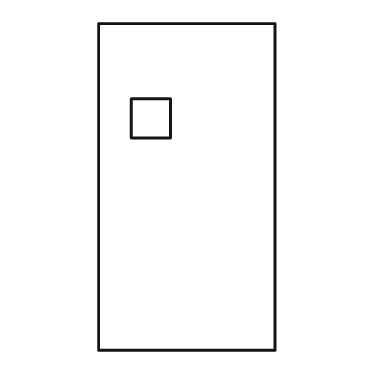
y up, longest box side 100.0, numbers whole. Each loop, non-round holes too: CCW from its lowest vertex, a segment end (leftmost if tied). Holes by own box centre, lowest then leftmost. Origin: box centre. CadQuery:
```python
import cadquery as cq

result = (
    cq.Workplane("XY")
    .moveTo(-27.0, -50.0)
    .lineTo(27.0, -50.0)
    .lineTo(27.0, 50.0)
    .lineTo(-27.0, 50.0)
    .close()
    .moveTo(-17.0, 15.0)
    .lineTo(-5.0, 15.0)
    .lineTo(-5.0, 27.0)
    .lineTo(-17.0, 27.0)
    .close()
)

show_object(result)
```